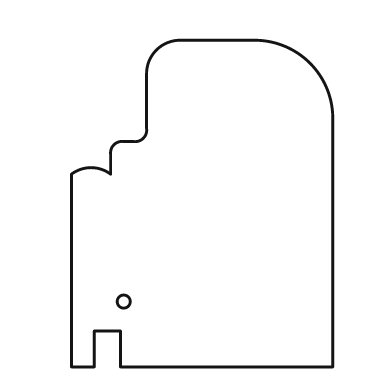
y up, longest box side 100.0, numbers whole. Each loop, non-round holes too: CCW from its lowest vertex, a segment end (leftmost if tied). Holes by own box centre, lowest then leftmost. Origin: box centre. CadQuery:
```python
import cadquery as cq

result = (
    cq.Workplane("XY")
    .moveTo(-40.0, -50.0)
    .lineTo(-33.0, -50.0)
    .lineTo(-33.0, -39.0)
    .lineTo(-25.0, -39.0)
    .lineTo(-25.0, -50.0)
    .lineTo(40.0, -50.0)
    .lineTo(40.0, 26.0)
    .threePointArc((33.0, 43.0), (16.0, 50.0))
    .lineTo(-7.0, 50.0)
    .threePointArc((-14.0, 47.0), (-17.0, 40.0))
    .lineTo(-17.0, 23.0)
    .threePointArc((-18.0, 20.0), (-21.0, 19.0))
    .lineTo(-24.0, 19.0)
    .threePointArc((-27.0, 18.0), (-28.0, 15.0))
    .lineTo(-28.0, 9.0)
    .threePointArc((-34.0, 11.0), (-40.0, 9.0))
    .close()
    .moveTo(-24.0, -30.0)
    .circle(2.0)
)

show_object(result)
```